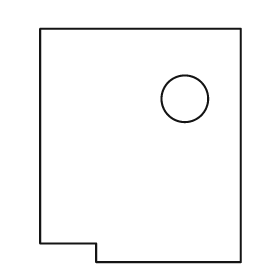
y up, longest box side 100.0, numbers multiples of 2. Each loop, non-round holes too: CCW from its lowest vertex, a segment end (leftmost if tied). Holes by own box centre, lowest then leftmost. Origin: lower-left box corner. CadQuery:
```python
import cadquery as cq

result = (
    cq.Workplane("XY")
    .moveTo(24.0, 0.0)
    .lineTo(86.0, 0.0)
    .lineTo(86.0, 100.0)
    .lineTo(0.0, 100.0)
    .lineTo(0.0, 8.0)
    .lineTo(24.0, 8.0)
    .close()
    .moveTo(62.0, 70.0)
    .circle(10.0)
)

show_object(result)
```